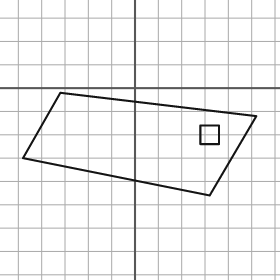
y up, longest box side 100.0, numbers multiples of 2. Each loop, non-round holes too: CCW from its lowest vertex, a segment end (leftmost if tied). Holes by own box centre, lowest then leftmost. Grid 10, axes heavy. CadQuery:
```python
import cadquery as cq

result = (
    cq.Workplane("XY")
    .moveTo(32.0, -46.0)
    .lineTo(52.0, -12.0)
    .lineTo(-32.0, -2.0)
    .lineTo(-48.0, -30.0)
    .close()
    .moveTo(28.0, -24.0)
    .lineTo(36.0, -24.0)
    .lineTo(36.0, -16.0)
    .lineTo(28.0, -16.0)
    .close()
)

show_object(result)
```